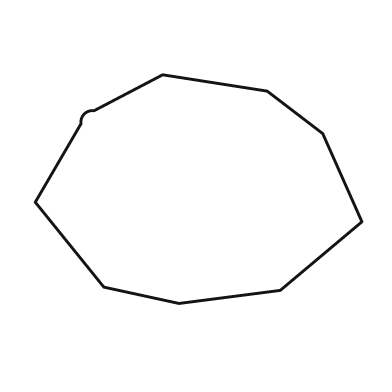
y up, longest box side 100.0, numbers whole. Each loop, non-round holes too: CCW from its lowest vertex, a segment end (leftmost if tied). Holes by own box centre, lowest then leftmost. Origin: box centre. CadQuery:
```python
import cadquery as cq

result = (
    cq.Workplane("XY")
    .moveTo(-6.0, -35.0)
    .lineTo(25.0, -31.0)
    .lineTo(50.0, -10.0)
    .lineTo(38.0, 17.0)
    .lineTo(21.0, 30.0)
    .lineTo(-11.0, 35.0)
    .lineTo(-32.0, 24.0)
    .threePointArc((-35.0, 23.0), (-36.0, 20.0))
    .lineTo(-50.0, -4.0)
    .lineTo(-29.0, -30.0)
    .close()
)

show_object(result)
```